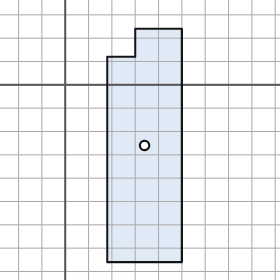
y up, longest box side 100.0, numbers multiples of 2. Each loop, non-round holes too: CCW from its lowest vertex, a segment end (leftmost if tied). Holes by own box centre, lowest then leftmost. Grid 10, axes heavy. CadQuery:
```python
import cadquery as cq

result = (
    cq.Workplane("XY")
    .moveTo(18.0, -76.0)
    .lineTo(50.0, -76.0)
    .lineTo(50.0, 24.0)
    .lineTo(30.0, 24.0)
    .lineTo(30.0, 12.0)
    .lineTo(18.0, 12.0)
    .close()
    .moveTo(34.0, -26.0)
    .circle(2.0)
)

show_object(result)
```